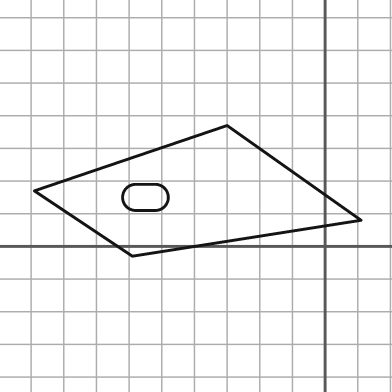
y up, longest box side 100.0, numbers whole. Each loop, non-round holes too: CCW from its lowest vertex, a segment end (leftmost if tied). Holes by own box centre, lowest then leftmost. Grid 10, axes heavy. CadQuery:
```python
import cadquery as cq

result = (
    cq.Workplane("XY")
    .moveTo(-59.0, -3.0)
    .lineTo(11.0, 8.0)
    .lineTo(-30.0, 37.0)
    .lineTo(-89.0, 17.0)
    .close()
    .moveTo(-58.0, 11.0)
    .lineTo(-52.0, 11.0)
    .threePointArc((-48.0, 15.0), (-52.0, 19.0))
    .lineTo(-58.0, 19.0)
    .threePointArc((-62.0, 15.0), (-58.0, 11.0))
    .close()
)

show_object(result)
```